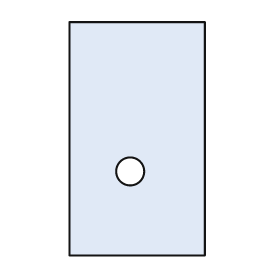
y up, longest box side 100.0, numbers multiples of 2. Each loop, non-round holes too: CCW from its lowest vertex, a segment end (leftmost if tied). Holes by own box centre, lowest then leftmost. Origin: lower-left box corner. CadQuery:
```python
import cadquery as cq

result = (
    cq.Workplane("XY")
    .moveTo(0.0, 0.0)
    .lineTo(58.0, 0.0)
    .lineTo(58.0, 100.0)
    .lineTo(0.0, 100.0)
    .close()
    .moveTo(26.0, 36.0)
    .circle(6.0)
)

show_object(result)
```